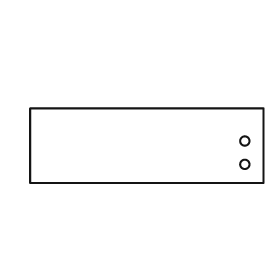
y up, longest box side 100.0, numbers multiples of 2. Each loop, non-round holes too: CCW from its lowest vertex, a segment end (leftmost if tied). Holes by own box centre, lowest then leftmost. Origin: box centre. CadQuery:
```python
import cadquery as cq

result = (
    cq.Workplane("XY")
    .moveTo(-50.0, -16.0)
    .lineTo(50.0, -16.0)
    .lineTo(50.0, 16.0)
    .lineTo(-50.0, 16.0)
    .close()
    .moveTo(42.0, -8.0)
    .circle(2.0)
    .moveTo(42.0, 2.0)
    .circle(2.0)
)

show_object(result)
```